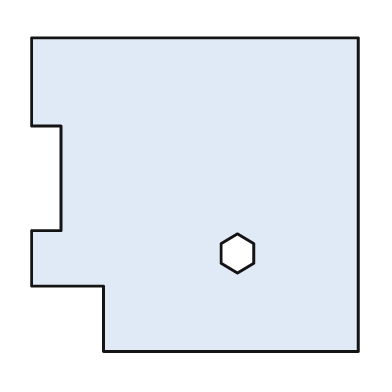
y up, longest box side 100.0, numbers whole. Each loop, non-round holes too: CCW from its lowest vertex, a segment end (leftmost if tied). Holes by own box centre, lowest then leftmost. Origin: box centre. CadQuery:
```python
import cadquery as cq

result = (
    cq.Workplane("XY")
    .moveTo(-28.0, -48.0)
    .lineTo(50.0, -48.0)
    .lineTo(50.0, 48.0)
    .lineTo(-50.0, 48.0)
    .lineTo(-50.0, 21.0)
    .lineTo(-41.0, 21.0)
    .lineTo(-41.0, -11.0)
    .lineTo(-50.0, -11.0)
    .lineTo(-50.0, -28.0)
    .lineTo(-28.0, -28.0)
    .close()
    .moveTo(13.0, -24.0)
    .lineTo(18.0, -21.0)
    .lineTo(18.0, -15.0)
    .lineTo(13.0, -12.0)
    .lineTo(8.0, -15.0)
    .lineTo(8.0, -21.0)
    .close()
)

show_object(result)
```